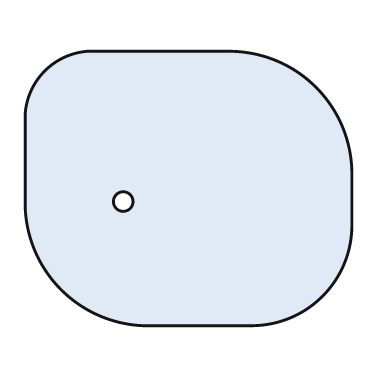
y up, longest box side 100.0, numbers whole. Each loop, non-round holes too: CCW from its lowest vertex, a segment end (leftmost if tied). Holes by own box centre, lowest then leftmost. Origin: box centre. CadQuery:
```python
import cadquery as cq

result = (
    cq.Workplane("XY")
    .moveTo(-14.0, -42.0)
    .lineTo(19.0, -42.0)
    .threePointArc((41.0, -33.0), (50.0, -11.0))
    .lineTo(50.0, 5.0)
    .threePointArc((39.0, 31.0), (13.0, 42.0))
    .lineTo(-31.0, 42.0)
    .threePointArc((-44.0, 36.0), (-50.0, 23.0))
    .lineTo(-50.0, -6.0)
    .threePointArc((-39.0, -31.0), (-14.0, -42.0))
    .close()
    .moveTo(-20.0, -4.0)
    .circle(3.0)
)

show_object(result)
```